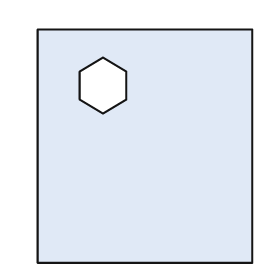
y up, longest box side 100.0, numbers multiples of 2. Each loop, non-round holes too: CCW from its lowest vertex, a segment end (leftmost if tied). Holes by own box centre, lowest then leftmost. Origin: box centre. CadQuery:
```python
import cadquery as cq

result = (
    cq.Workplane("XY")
    .moveTo(-46.0, -50.0)
    .lineTo(46.0, -50.0)
    .lineTo(46.0, 50.0)
    .lineTo(-46.0, 50.0)
    .close()
    .moveTo(-18.0, 14.0)
    .lineTo(-8.0, 20.0)
    .lineTo(-8.0, 32.0)
    .lineTo(-18.0, 38.0)
    .lineTo(-28.0, 32.0)
    .lineTo(-28.0, 20.0)
    .close()
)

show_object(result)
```